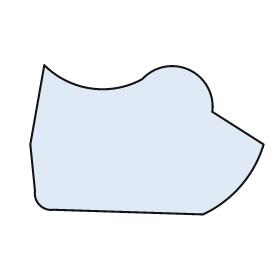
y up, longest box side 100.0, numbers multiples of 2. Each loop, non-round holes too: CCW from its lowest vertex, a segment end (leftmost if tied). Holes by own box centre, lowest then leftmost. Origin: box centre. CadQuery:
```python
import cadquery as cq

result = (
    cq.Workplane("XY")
    .moveTo(24.0, -32.0)
    .threePointArc((40.0, -20.0), (50.0, -2.0))
    .lineTo(28.0, 12.0)
    .threePointArc((18.0, 30.0), (-2.0, 26.0))
    .threePointArc((-24.0, 22.0), (-44.0, 32.0))
    .lineTo(-50.0, -2.0)
    .lineTo(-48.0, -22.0)
    .threePointArc((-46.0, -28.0), (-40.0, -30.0))
    .close()
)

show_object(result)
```